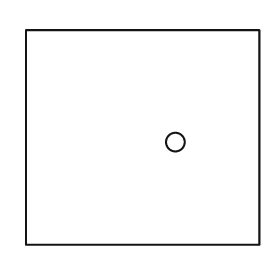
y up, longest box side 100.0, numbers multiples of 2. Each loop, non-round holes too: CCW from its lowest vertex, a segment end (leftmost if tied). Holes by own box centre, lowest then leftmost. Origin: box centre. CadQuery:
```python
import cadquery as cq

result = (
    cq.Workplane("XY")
    .moveTo(-50.0, -46.0)
    .lineTo(50.0, -46.0)
    .lineTo(50.0, 46.0)
    .lineTo(-50.0, 46.0)
    .close()
    .moveTo(14.0, -2.0)
    .circle(4.0)
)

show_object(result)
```